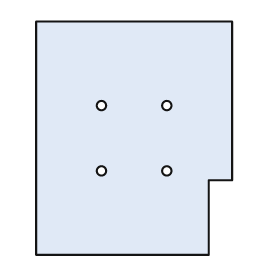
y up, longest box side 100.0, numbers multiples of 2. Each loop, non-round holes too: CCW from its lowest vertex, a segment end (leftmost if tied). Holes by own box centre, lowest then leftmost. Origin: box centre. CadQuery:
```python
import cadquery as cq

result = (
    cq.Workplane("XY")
    .moveTo(-42.0, -50.0)
    .lineTo(32.0, -50.0)
    .lineTo(32.0, -18.0)
    .lineTo(42.0, -18.0)
    .lineTo(42.0, 50.0)
    .lineTo(-42.0, 50.0)
    .close()
    .moveTo(-14.0, -14.0)
    .circle(2.0)
    .moveTo(14.0, -14.0)
    .circle(2.0)
    .moveTo(-14.0, 14.0)
    .circle(2.0)
    .moveTo(14.0, 14.0)
    .circle(2.0)
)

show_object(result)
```